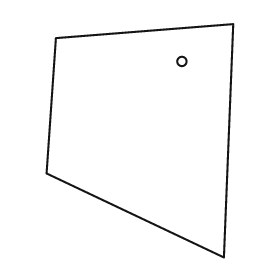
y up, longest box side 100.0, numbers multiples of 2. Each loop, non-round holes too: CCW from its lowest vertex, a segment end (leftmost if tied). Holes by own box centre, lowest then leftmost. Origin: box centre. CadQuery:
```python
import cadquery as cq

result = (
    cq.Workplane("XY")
    .moveTo(36.0, -50.0)
    .lineTo(40.0, 50.0)
    .lineTo(-36.0, 44.0)
    .lineTo(-40.0, -14.0)
    .close()
    .moveTo(18.0, 34.0)
    .circle(2.0)
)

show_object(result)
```